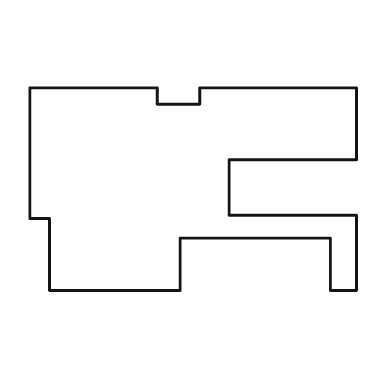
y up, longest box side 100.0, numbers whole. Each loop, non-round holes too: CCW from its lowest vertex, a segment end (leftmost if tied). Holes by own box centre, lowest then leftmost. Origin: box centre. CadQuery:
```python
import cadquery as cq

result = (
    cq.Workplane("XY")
    .moveTo(-44.0, -31.0)
    .lineTo(-4.0, -31.0)
    .lineTo(-4.0, -15.0)
    .lineTo(42.0, -15.0)
    .lineTo(42.0, -31.0)
    .lineTo(50.0, -31.0)
    .lineTo(50.0, -8.0)
    .lineTo(11.0, -8.0)
    .lineTo(11.0, 9.0)
    .lineTo(50.0, 9.0)
    .lineTo(50.0, 31.0)
    .lineTo(2.0, 31.0)
    .lineTo(2.0, 26.0)
    .lineTo(-11.0, 26.0)
    .lineTo(-11.0, 31.0)
    .lineTo(-50.0, 31.0)
    .lineTo(-50.0, -9.0)
    .lineTo(-44.0, -9.0)
    .close()
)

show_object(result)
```